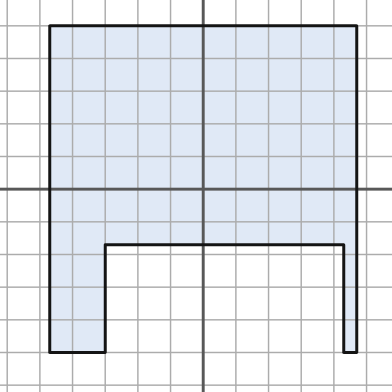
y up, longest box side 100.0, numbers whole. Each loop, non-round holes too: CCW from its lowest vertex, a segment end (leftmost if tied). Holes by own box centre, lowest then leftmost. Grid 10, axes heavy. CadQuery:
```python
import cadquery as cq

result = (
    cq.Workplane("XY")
    .moveTo(-47.0, -50.0)
    .lineTo(-30.0, -50.0)
    .lineTo(-30.0, -17.0)
    .lineTo(43.0, -17.0)
    .lineTo(43.0, -50.0)
    .lineTo(47.0, -50.0)
    .lineTo(47.0, 50.0)
    .lineTo(-47.0, 50.0)
    .close()
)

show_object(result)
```